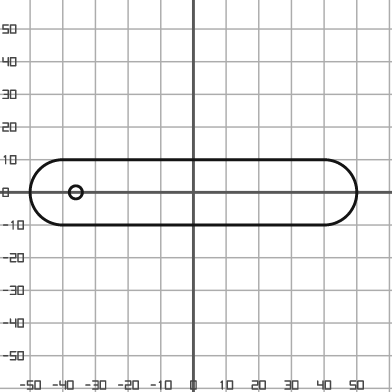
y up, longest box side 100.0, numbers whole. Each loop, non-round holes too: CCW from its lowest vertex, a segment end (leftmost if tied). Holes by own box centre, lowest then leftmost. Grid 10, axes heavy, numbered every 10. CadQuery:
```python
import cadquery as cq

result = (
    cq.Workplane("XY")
    .moveTo(-40.0, -10.0)
    .lineTo(40.0, -10.0)
    .threePointArc((50.0, 0.0), (40.0, 10.0))
    .lineTo(-40.0, 10.0)
    .threePointArc((-50.0, 0.0), (-40.0, -10.0))
    .close()
    .moveTo(-36.0, 0.0)
    .circle(2.0)
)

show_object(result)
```